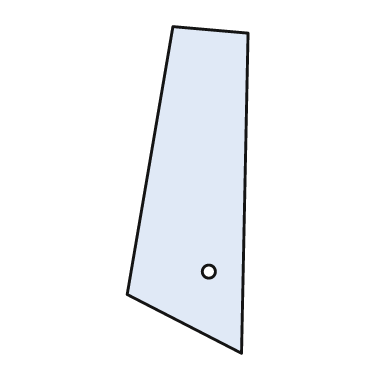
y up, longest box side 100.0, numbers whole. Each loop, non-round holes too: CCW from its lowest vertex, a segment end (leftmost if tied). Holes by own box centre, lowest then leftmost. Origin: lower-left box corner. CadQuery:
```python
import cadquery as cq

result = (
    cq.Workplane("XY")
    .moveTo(35.0, 0.0)
    .lineTo(37.0, 98.0)
    .lineTo(14.0, 100.0)
    .lineTo(0.0, 18.0)
    .close()
    .moveTo(25.0, 25.0)
    .circle(2.0)
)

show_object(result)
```